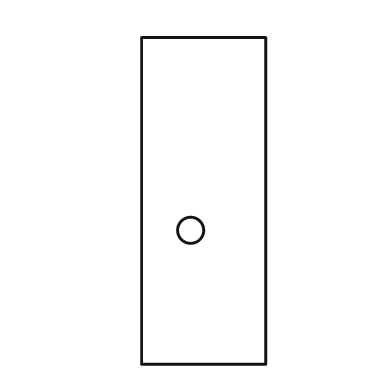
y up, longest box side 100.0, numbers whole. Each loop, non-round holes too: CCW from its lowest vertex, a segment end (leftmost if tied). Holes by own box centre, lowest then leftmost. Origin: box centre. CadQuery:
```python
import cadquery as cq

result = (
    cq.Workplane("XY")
    .moveTo(-19.0, -50.0)
    .lineTo(19.0, -50.0)
    .lineTo(19.0, 50.0)
    .lineTo(-19.0, 50.0)
    .close()
    .moveTo(-4.0, -9.0)
    .circle(4.0)
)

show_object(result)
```